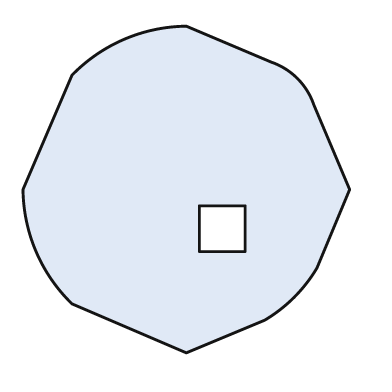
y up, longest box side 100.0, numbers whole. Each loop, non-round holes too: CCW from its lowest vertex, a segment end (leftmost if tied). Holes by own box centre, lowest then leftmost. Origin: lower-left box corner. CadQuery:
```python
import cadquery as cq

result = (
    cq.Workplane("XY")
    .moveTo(50.0, 0.0)
    .lineTo(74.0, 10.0)
    .threePointArc((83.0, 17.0), (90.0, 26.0))
    .lineTo(100.0, 50.0)
    .lineTo(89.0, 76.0)
    .threePointArc((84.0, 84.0), (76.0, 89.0))
    .lineTo(50.0, 100.0)
    .threePointArc((31.0, 96.0), (15.0, 85.0))
    .lineTo(0.0, 50.0)
    .threePointArc((4.0, 31.0), (15.0, 15.0))
    .close()
    .moveTo(54.0, 31.0)
    .lineTo(68.0, 31.0)
    .lineTo(68.0, 45.0)
    .lineTo(54.0, 45.0)
    .close()
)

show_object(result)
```